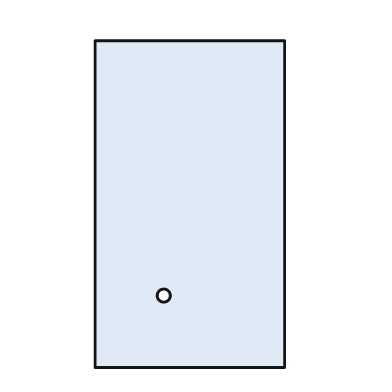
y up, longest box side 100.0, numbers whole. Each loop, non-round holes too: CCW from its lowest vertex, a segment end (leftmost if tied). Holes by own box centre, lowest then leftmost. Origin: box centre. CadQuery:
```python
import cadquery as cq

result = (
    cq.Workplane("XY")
    .moveTo(-29.0, -50.0)
    .lineTo(29.0, -50.0)
    .lineTo(29.0, 50.0)
    .lineTo(-29.0, 50.0)
    .close()
    .moveTo(-8.0, -28.0)
    .circle(2.0)
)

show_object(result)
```